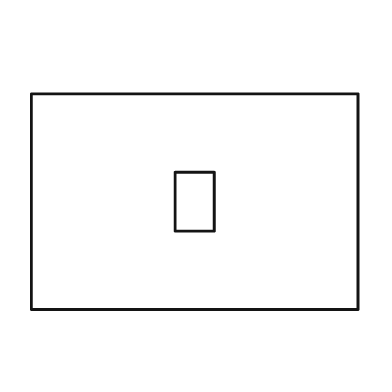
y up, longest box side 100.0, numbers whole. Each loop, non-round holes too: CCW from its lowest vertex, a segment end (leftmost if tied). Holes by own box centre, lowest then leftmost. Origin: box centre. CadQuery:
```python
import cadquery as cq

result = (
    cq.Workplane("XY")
    .moveTo(-50.0, -33.0)
    .lineTo(50.0, -33.0)
    .lineTo(50.0, 33.0)
    .lineTo(-50.0, 33.0)
    .close()
    .moveTo(-6.0, -9.0)
    .lineTo(6.0, -9.0)
    .lineTo(6.0, 9.0)
    .lineTo(-6.0, 9.0)
    .close()
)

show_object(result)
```